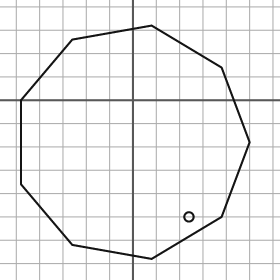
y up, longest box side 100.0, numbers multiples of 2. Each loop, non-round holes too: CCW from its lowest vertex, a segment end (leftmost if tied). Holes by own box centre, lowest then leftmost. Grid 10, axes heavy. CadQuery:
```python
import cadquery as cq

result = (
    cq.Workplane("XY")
    .moveTo(8.0, -68.0)
    .lineTo(38.0, -50.0)
    .lineTo(50.0, -18.0)
    .lineTo(38.0, 14.0)
    .lineTo(8.0, 32.0)
    .lineTo(-26.0, 26.0)
    .lineTo(-48.0, 0.0)
    .lineTo(-48.0, -36.0)
    .lineTo(-26.0, -62.0)
    .close()
    .moveTo(24.0, -50.0)
    .circle(2.0)
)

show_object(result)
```